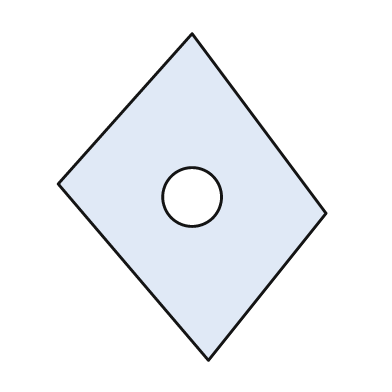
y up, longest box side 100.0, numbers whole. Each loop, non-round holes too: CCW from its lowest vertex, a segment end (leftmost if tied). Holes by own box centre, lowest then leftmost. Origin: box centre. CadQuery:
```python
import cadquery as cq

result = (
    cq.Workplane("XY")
    .moveTo(5.0, -50.0)
    .lineTo(41.0, -5.0)
    .lineTo(0.0, 50.0)
    .lineTo(-41.0, 4.0)
    .close()
    .moveTo(0.0, 0.0)
    .circle(9.0)
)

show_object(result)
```